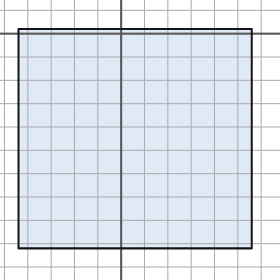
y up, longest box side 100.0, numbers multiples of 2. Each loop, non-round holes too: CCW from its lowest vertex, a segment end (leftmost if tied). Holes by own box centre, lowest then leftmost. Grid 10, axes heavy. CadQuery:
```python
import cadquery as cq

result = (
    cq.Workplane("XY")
    .moveTo(-44.0, -92.0)
    .lineTo(56.0, -92.0)
    .lineTo(56.0, 2.0)
    .lineTo(-44.0, 2.0)
    .close()
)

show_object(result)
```